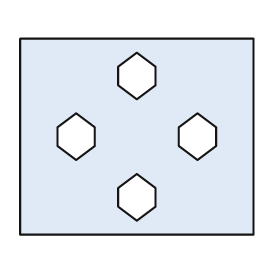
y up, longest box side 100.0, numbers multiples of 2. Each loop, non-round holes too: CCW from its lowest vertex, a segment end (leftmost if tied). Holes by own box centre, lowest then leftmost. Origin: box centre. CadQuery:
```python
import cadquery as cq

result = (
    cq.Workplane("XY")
    .moveTo(-50.0, -42.0)
    .lineTo(50.0, -42.0)
    .lineTo(50.0, 42.0)
    .lineTo(-50.0, 42.0)
    .close()
    .moveTo(0.0, -36.0)
    .lineTo(8.0, -30.0)
    .lineTo(8.0, -22.0)
    .lineTo(0.0, -16.0)
    .lineTo(-8.0, -22.0)
    .lineTo(-8.0, -30.0)
    .close()
    .moveTo(-26.0, -10.0)
    .lineTo(-18.0, -4.0)
    .lineTo(-18.0, 4.0)
    .lineTo(-26.0, 10.0)
    .lineTo(-34.0, 4.0)
    .lineTo(-34.0, -4.0)
    .close()
    .moveTo(26.0, -10.0)
    .lineTo(34.0, -4.0)
    .lineTo(34.0, 4.0)
    .lineTo(26.0, 10.0)
    .lineTo(18.0, 4.0)
    .lineTo(18.0, -4.0)
    .close()
    .moveTo(0.0, 16.0)
    .lineTo(8.0, 22.0)
    .lineTo(8.0, 30.0)
    .lineTo(0.0, 36.0)
    .lineTo(-8.0, 30.0)
    .lineTo(-8.0, 22.0)
    .close()
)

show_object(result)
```